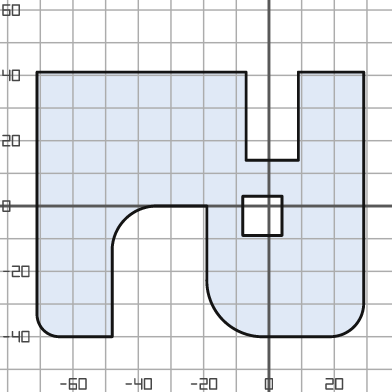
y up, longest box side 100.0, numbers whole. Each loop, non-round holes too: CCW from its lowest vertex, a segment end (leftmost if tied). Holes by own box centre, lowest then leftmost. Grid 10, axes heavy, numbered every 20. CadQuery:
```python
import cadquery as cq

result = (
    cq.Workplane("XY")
    .moveTo(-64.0, -40.0)
    .lineTo(-48.0, -40.0)
    .lineTo(-48.0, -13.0)
    .threePointArc((-44.0, -4.0), (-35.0, 0.0))
    .lineTo(-19.0, 0.0)
    .lineTo(-19.0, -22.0)
    .threePointArc((-14.0, -35.0), (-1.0, -40.0))
    .lineTo(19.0, -40.0)
    .threePointArc((26.0, -37.0), (29.0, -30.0))
    .lineTo(29.0, 41.0)
    .lineTo(9.0, 41.0)
    .lineTo(9.0, 14.0)
    .lineTo(-7.0, 14.0)
    .lineTo(-7.0, 41.0)
    .lineTo(-71.0, 41.0)
    .lineTo(-71.0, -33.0)
    .threePointArc((-69.0, -38.0), (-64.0, -40.0))
    .close()
    .moveTo(-8.0, -9.0)
    .lineTo(4.0, -9.0)
    .lineTo(4.0, 3.0)
    .lineTo(-8.0, 3.0)
    .close()
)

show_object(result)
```